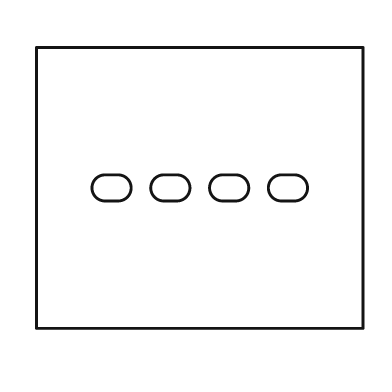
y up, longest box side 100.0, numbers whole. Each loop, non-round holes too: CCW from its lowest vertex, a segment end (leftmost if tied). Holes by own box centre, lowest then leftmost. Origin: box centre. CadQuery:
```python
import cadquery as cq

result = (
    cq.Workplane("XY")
    .moveTo(-50.0, -43.0)
    .lineTo(50.0, -43.0)
    .lineTo(50.0, 43.0)
    .lineTo(-50.0, 43.0)
    .close()
    .moveTo(-29.0, -4.0)
    .lineTo(-25.0, -4.0)
    .threePointArc((-21.0, 0.0), (-25.0, 4.0))
    .lineTo(-29.0, 4.0)
    .threePointArc((-33.0, 0.0), (-29.0, -4.0))
    .close()
    .moveTo(-11.0, -4.0)
    .lineTo(-7.0, -4.0)
    .threePointArc((-3.0, 0.0), (-7.0, 4.0))
    .lineTo(-11.0, 4.0)
    .threePointArc((-15.0, 0.0), (-11.0, -4.0))
    .close()
    .moveTo(7.0, -4.0)
    .lineTo(11.0, -4.0)
    .threePointArc((15.0, 0.0), (11.0, 4.0))
    .lineTo(7.0, 4.0)
    .threePointArc((3.0, 0.0), (7.0, -4.0))
    .close()
    .moveTo(25.0, -4.0)
    .lineTo(29.0, -4.0)
    .threePointArc((33.0, 0.0), (29.0, 4.0))
    .lineTo(25.0, 4.0)
    .threePointArc((21.0, 0.0), (25.0, -4.0))
    .close()
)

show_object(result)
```